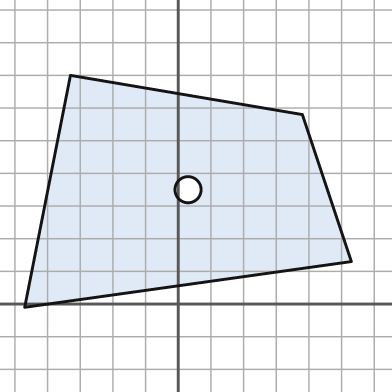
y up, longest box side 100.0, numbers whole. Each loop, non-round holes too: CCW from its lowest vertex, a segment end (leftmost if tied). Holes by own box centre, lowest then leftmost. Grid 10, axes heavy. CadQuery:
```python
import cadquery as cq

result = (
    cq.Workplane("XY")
    .moveTo(-47.0, -1.0)
    .lineTo(53.0, 13.0)
    .lineTo(38.0, 58.0)
    .lineTo(-33.0, 70.0)
    .close()
    .moveTo(3.0, 35.0)
    .circle(4.0)
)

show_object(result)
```